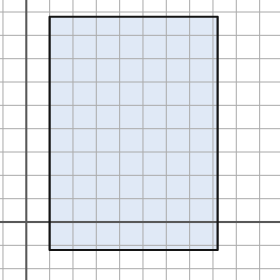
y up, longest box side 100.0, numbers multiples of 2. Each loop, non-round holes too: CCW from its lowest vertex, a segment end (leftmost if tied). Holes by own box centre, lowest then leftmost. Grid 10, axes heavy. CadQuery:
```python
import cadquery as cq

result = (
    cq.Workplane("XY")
    .moveTo(10.0, -12.0)
    .lineTo(82.0, -12.0)
    .lineTo(82.0, 88.0)
    .lineTo(10.0, 88.0)
    .close()
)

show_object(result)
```